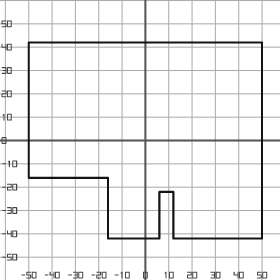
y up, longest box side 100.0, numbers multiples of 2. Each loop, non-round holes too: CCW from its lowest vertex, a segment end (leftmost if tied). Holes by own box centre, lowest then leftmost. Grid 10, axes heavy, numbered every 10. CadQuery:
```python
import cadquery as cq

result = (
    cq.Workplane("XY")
    .moveTo(-16.0, -42.0)
    .lineTo(6.0, -42.0)
    .lineTo(6.0, -22.0)
    .lineTo(12.0, -22.0)
    .lineTo(12.0, -42.0)
    .lineTo(50.0, -42.0)
    .lineTo(50.0, 42.0)
    .lineTo(-50.0, 42.0)
    .lineTo(-50.0, -16.0)
    .lineTo(-16.0, -16.0)
    .close()
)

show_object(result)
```